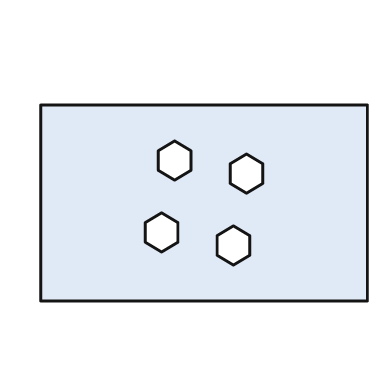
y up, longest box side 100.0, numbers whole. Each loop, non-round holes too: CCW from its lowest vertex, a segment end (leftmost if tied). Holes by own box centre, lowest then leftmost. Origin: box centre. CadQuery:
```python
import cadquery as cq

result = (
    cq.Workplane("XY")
    .moveTo(-50.0, -30.0)
    .lineTo(50.0, -30.0)
    .lineTo(50.0, 30.0)
    .lineTo(-50.0, 30.0)
    .close()
    .moveTo(9.0, -19.0)
    .lineTo(14.0, -16.0)
    .lineTo(14.0, -10.0)
    .lineTo(9.0, -7.0)
    .lineTo(4.0, -10.0)
    .lineTo(4.0, -16.0)
    .close()
    .moveTo(-13.0, -15.0)
    .lineTo(-8.0, -12.0)
    .lineTo(-8.0, -6.0)
    .lineTo(-13.0, -3.0)
    .lineTo(-18.0, -6.0)
    .lineTo(-18.0, -12.0)
    .close()
    .moveTo(13.0, 3.0)
    .lineTo(18.0, 6.0)
    .lineTo(18.0, 12.0)
    .lineTo(13.0, 15.0)
    .lineTo(8.0, 12.0)
    .lineTo(8.0, 6.0)
    .close()
    .moveTo(-9.0, 7.0)
    .lineTo(-4.0, 10.0)
    .lineTo(-4.0, 16.0)
    .lineTo(-9.0, 19.0)
    .lineTo(-14.0, 16.0)
    .lineTo(-14.0, 10.0)
    .close()
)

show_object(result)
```